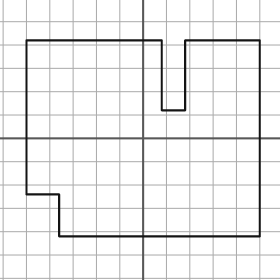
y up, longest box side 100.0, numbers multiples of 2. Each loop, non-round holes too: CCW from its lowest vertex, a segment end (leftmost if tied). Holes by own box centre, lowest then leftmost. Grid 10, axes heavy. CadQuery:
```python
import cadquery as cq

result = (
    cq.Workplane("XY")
    .moveTo(-36.0, -42.0)
    .lineTo(50.0, -42.0)
    .lineTo(50.0, 42.0)
    .lineTo(18.0, 42.0)
    .lineTo(18.0, 12.0)
    .lineTo(8.0, 12.0)
    .lineTo(8.0, 42.0)
    .lineTo(-50.0, 42.0)
    .lineTo(-50.0, -24.0)
    .lineTo(-36.0, -24.0)
    .close()
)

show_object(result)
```